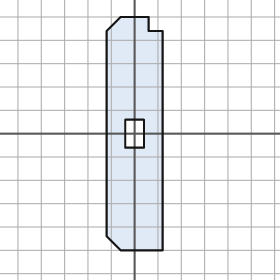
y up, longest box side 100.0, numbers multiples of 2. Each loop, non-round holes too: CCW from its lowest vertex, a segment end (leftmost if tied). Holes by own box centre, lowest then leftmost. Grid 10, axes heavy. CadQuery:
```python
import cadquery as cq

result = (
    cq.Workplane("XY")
    .moveTo(-6.0, -50.0)
    .lineTo(12.0, -50.0)
    .lineTo(12.0, 44.0)
    .lineTo(6.0, 44.0)
    .lineTo(6.0, 50.0)
    .lineTo(-6.0, 50.0)
    .lineTo(-12.0, 44.0)
    .lineTo(-12.0, -44.0)
    .close()
    .moveTo(-4.0, -6.0)
    .lineTo(4.0, -6.0)
    .lineTo(4.0, 6.0)
    .lineTo(-4.0, 6.0)
    .close()
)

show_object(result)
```